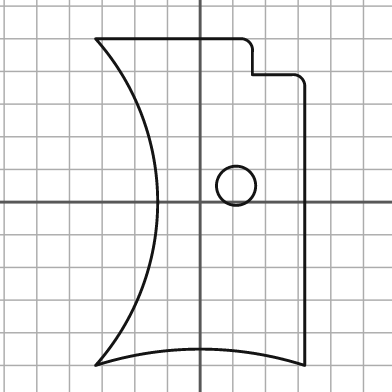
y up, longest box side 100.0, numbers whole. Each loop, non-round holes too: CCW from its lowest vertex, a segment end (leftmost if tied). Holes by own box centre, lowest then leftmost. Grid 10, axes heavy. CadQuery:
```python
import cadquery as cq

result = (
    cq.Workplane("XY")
    .moveTo(-32.0, -50.0)
    .threePointArc((0.0, -45.0), (32.0, -50.0))
    .lineTo(32.0, 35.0)
    .threePointArc((31.0, 38.0), (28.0, 39.0))
    .lineTo(16.0, 39.0)
    .lineTo(16.0, 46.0)
    .threePointArc((15.0, 49.0), (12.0, 50.0))
    .lineTo(-32.0, 50.0)
    .threePointArc((-13.0, 0.0), (-32.0, -50.0))
    .close()
    .moveTo(11.0, 5.0)
    .circle(6.0)
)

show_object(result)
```